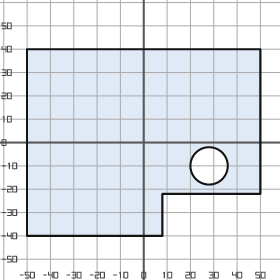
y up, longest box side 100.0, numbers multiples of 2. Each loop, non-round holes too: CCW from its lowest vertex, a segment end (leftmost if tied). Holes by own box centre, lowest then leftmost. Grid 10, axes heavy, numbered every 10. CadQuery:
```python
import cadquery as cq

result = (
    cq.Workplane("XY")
    .moveTo(-50.0, -40.0)
    .lineTo(8.0, -40.0)
    .lineTo(8.0, -22.0)
    .lineTo(50.0, -22.0)
    .lineTo(50.0, 40.0)
    .lineTo(-50.0, 40.0)
    .close()
    .moveTo(28.0, -10.0)
    .circle(8.0)
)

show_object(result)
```